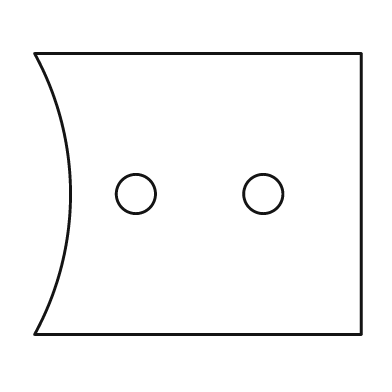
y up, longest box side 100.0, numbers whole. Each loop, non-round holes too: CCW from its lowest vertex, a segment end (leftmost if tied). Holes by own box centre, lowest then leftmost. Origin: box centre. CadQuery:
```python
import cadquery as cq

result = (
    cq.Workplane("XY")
    .moveTo(-50.0, -43.0)
    .lineTo(50.0, -43.0)
    .lineTo(50.0, 43.0)
    .lineTo(-50.0, 43.0)
    .threePointArc((-39.0, 0.0), (-50.0, -43.0))
    .close()
    .moveTo(-19.0, 0.0)
    .circle(6.0)
    .moveTo(20.0, 0.0)
    .circle(6.0)
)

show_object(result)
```